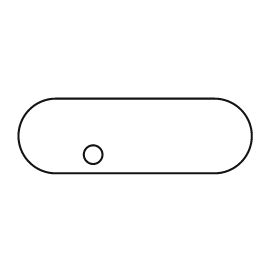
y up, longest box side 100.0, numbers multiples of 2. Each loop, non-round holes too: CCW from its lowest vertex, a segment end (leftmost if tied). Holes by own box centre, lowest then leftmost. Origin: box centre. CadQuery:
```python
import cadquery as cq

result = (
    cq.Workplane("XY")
    .moveTo(-34.0, -16.0)
    .lineTo(34.0, -16.0)
    .threePointArc((50.0, 0.0), (34.0, 16.0))
    .lineTo(-34.0, 16.0)
    .threePointArc((-50.0, 0.0), (-34.0, -16.0))
    .close()
    .moveTo(-18.0, -8.0)
    .circle(4.0)
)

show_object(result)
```